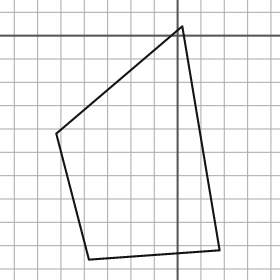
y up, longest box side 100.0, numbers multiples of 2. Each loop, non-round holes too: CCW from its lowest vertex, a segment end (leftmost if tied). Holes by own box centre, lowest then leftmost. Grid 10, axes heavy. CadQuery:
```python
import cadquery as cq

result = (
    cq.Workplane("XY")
    .moveTo(-38.0, -96.0)
    .lineTo(18.0, -92.0)
    .lineTo(2.0, 4.0)
    .lineTo(-52.0, -42.0)
    .close()
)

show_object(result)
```